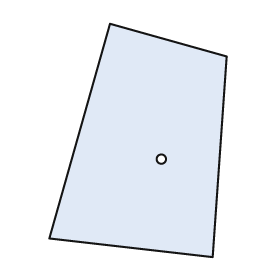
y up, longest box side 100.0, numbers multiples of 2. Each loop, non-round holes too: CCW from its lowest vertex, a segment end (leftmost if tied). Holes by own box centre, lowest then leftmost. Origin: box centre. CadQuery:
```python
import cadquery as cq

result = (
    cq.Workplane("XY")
    .moveTo(32.0, -50.0)
    .lineTo(38.0, 36.0)
    .lineTo(-12.0, 50.0)
    .lineTo(-38.0, -42.0)
    .close()
    .moveTo(10.0, -8.0)
    .circle(2.0)
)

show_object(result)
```